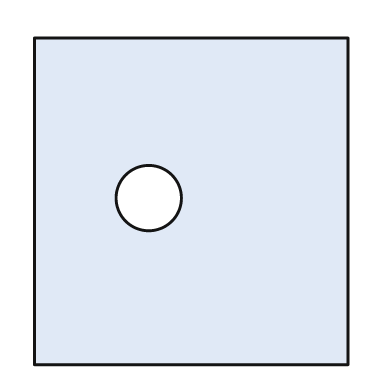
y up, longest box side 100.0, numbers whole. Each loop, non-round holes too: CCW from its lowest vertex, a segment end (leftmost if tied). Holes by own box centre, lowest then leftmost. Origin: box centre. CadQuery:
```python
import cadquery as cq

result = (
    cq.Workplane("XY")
    .moveTo(-48.0, -50.0)
    .lineTo(48.0, -50.0)
    .lineTo(48.0, 50.0)
    .lineTo(-48.0, 50.0)
    .close()
    .moveTo(-13.0, 1.0)
    .circle(10.0)
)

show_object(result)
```